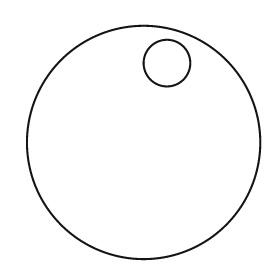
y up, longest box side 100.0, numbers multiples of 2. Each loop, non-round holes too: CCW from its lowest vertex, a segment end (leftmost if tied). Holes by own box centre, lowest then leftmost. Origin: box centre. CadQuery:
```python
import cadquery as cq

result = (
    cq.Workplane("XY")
    .moveTo(0.0, 0.0)
    .circle(50.0)
    .moveTo(10.0, 34.0)
    .circle(10.0)
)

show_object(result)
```